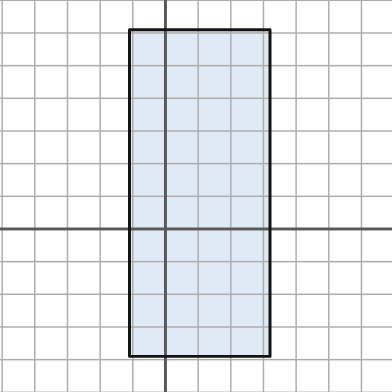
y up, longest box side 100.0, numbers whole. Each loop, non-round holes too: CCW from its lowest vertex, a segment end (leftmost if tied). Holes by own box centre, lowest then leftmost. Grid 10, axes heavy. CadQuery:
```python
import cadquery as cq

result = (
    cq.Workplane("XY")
    .moveTo(-11.0, -39.0)
    .lineTo(32.0, -39.0)
    .lineTo(32.0, 61.0)
    .lineTo(-11.0, 61.0)
    .close()
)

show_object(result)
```